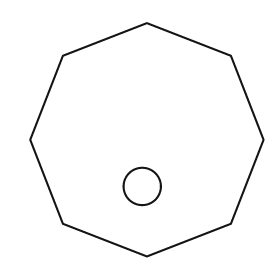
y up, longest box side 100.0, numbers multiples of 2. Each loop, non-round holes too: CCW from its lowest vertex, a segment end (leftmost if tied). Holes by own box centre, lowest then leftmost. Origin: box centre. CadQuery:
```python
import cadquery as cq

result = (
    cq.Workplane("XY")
    .moveTo(0.0, -50.0)
    .lineTo(36.0, -36.0)
    .lineTo(50.0, 0.0)
    .lineTo(36.0, 36.0)
    .lineTo(0.0, 50.0)
    .lineTo(-36.0, 36.0)
    .lineTo(-50.0, 0.0)
    .lineTo(-36.0, -36.0)
    .close()
    .moveTo(-2.0, -20.0)
    .circle(8.0)
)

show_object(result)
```